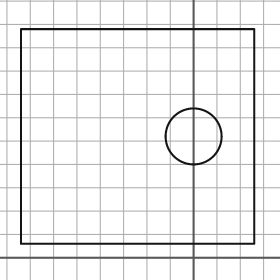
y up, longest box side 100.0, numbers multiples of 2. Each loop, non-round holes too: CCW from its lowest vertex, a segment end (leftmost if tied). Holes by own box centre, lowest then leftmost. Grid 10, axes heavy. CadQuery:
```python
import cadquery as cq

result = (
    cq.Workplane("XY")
    .moveTo(-74.0, 6.0)
    .lineTo(26.0, 6.0)
    .lineTo(26.0, 98.0)
    .lineTo(-74.0, 98.0)
    .close()
    .moveTo(0.0, 52.0)
    .circle(12.0)
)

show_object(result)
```